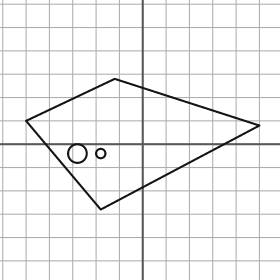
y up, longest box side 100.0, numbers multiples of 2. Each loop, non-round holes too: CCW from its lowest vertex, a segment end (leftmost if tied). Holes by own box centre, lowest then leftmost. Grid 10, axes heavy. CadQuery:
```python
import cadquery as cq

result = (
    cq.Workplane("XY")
    .moveTo(-18.0, -28.0)
    .lineTo(50.0, 8.0)
    .lineTo(-12.0, 28.0)
    .lineTo(-50.0, 10.0)
    .close()
    .moveTo(-28.0, -4.0)
    .circle(4.0)
    .moveTo(-18.0, -4.0)
    .circle(2.0)
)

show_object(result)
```